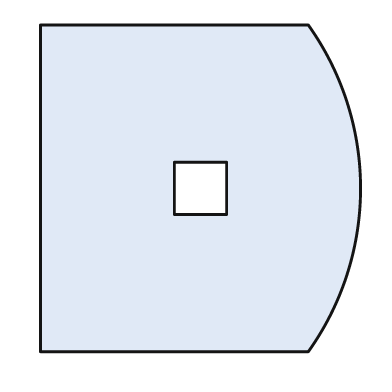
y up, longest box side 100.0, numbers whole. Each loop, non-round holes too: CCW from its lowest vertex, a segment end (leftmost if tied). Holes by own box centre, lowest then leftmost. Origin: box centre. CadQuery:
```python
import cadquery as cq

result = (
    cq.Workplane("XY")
    .moveTo(-49.0, -50.0)
    .lineTo(33.0, -50.0)
    .threePointArc((49.0, 0.0), (33.0, 50.0))
    .lineTo(-49.0, 50.0)
    .close()
    .moveTo(-8.0, -8.0)
    .lineTo(8.0, -8.0)
    .lineTo(8.0, 8.0)
    .lineTo(-8.0, 8.0)
    .close()
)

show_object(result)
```